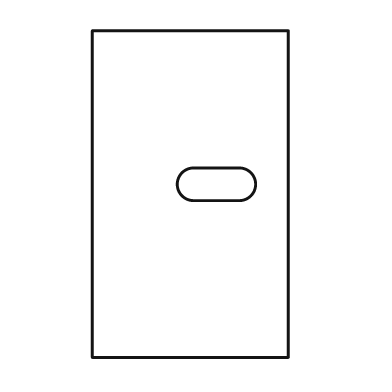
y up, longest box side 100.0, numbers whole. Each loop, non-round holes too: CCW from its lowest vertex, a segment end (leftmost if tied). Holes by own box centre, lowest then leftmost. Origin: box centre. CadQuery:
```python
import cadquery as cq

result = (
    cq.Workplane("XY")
    .moveTo(-30.0, -50.0)
    .lineTo(30.0, -50.0)
    .lineTo(30.0, 50.0)
    .lineTo(-30.0, 50.0)
    .close()
    .moveTo(1.0, -2.0)
    .lineTo(15.0, -2.0)
    .threePointArc((20.0, 3.0), (15.0, 8.0))
    .lineTo(1.0, 8.0)
    .threePointArc((-4.0, 3.0), (1.0, -2.0))
    .close()
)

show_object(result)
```